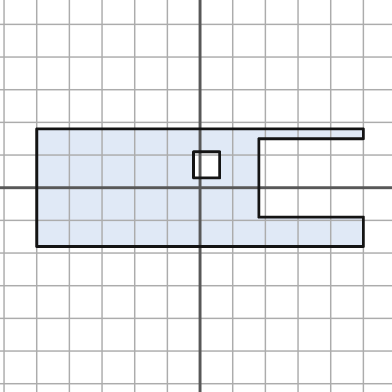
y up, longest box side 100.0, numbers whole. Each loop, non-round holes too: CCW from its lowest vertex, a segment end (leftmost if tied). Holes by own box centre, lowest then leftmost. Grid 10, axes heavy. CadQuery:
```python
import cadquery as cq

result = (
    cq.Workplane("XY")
    .moveTo(-50.0, -18.0)
    .lineTo(50.0, -18.0)
    .lineTo(50.0, -9.0)
    .lineTo(18.0, -9.0)
    .lineTo(18.0, 15.0)
    .lineTo(50.0, 15.0)
    .lineTo(50.0, 18.0)
    .lineTo(-50.0, 18.0)
    .close()
    .moveTo(-2.0, 3.0)
    .lineTo(6.0, 3.0)
    .lineTo(6.0, 11.0)
    .lineTo(-2.0, 11.0)
    .close()
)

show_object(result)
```